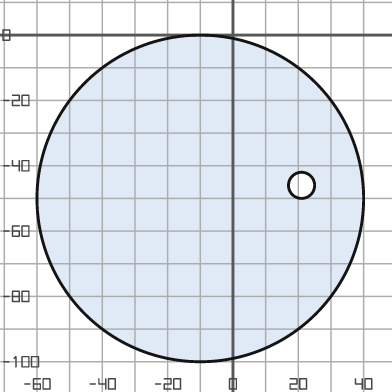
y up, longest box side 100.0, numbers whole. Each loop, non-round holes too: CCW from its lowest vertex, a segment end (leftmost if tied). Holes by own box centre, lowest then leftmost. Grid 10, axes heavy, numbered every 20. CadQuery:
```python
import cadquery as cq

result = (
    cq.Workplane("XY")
    .moveTo(-10.0, -50.0)
    .circle(50.0)
    .moveTo(21.0, -46.0)
    .circle(4.0)
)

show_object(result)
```